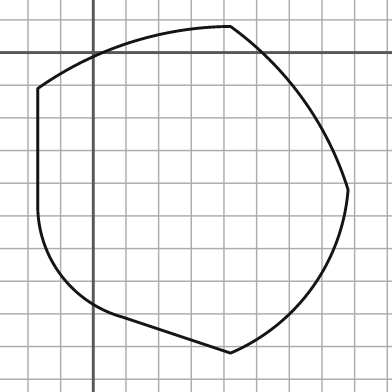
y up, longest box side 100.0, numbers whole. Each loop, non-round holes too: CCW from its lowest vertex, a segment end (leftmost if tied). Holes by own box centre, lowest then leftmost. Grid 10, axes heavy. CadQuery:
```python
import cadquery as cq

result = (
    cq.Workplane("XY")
    .moveTo(42.0, -92.0)
    .threePointArc((67.0, -72.0), (78.0, -42.0))
    .threePointArc((64.0, -14.0), (42.0, 8.0))
    .threePointArc((11.0, 3.0), (-17.0, -11.0))
    .lineTo(-17.0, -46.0)
    .threePointArc((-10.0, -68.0), (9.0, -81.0))
    .close()
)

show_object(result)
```